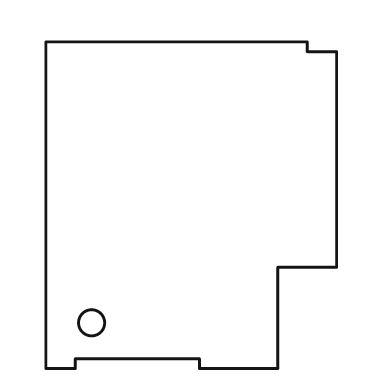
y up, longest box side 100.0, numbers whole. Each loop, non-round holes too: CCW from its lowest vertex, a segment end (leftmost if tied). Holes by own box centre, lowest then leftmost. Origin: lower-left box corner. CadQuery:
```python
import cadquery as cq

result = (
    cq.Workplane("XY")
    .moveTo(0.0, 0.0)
    .lineTo(9.0, 0.0)
    .lineTo(9.0, 3.0)
    .lineTo(47.0, 3.0)
    .lineTo(47.0, 0.0)
    .lineTo(71.0, 0.0)
    .lineTo(71.0, 31.0)
    .lineTo(89.0, 31.0)
    .lineTo(89.0, 97.0)
    .lineTo(80.0, 97.0)
    .lineTo(80.0, 100.0)
    .lineTo(0.0, 100.0)
    .close()
    .moveTo(14.0, 14.0)
    .circle(4.0)
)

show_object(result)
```